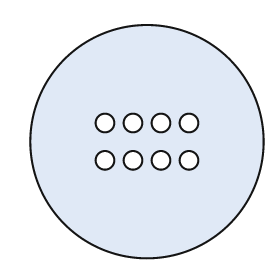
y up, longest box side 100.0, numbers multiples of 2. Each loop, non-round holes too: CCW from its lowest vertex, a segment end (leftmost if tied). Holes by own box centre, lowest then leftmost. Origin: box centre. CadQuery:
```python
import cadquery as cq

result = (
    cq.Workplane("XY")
    .moveTo(0.0, 0.0)
    .circle(50.0)
    .moveTo(-18.0, -8.0)
    .circle(4.0)
    .moveTo(-6.0, -8.0)
    .circle(4.0)
    .moveTo(6.0, -8.0)
    .circle(4.0)
    .moveTo(18.0, -8.0)
    .circle(4.0)
    .moveTo(-18.0, 8.0)
    .circle(4.0)
    .moveTo(-6.0, 8.0)
    .circle(4.0)
    .moveTo(6.0, 8.0)
    .circle(4.0)
    .moveTo(18.0, 8.0)
    .circle(4.0)
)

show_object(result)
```